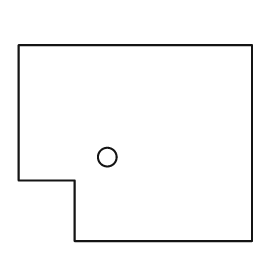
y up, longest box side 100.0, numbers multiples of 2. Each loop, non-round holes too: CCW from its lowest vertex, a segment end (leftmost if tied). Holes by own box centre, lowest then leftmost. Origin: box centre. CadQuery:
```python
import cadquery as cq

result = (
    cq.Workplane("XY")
    .moveTo(-26.0, -42.0)
    .lineTo(50.0, -42.0)
    .lineTo(50.0, 42.0)
    .lineTo(-50.0, 42.0)
    .lineTo(-50.0, -16.0)
    .lineTo(-26.0, -16.0)
    .close()
    .moveTo(-12.0, -6.0)
    .circle(4.0)
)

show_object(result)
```